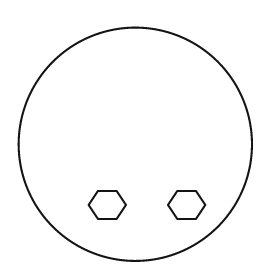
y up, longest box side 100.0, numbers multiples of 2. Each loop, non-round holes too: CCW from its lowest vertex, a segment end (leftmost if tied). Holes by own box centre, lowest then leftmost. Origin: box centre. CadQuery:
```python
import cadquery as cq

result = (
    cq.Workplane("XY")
    .moveTo(0.0, 0.0)
    .circle(50.0)
    .moveTo(-16.0, -32.0)
    .lineTo(-8.0, -32.0)
    .lineTo(-4.0, -26.0)
    .lineTo(-8.0, -20.0)
    .lineTo(-16.0, -20.0)
    .lineTo(-20.0, -26.0)
    .close()
    .moveTo(18.0, -32.0)
    .lineTo(26.0, -32.0)
    .lineTo(30.0, -26.0)
    .lineTo(26.0, -20.0)
    .lineTo(18.0, -20.0)
    .lineTo(14.0, -26.0)
    .close()
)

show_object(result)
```